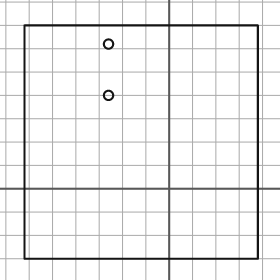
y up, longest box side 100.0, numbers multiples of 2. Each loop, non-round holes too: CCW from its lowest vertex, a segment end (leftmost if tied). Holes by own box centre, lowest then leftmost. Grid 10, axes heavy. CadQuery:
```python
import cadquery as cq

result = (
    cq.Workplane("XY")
    .moveTo(-62.0, -30.0)
    .lineTo(38.0, -30.0)
    .lineTo(38.0, 70.0)
    .lineTo(-62.0, 70.0)
    .close()
    .moveTo(-26.0, 40.0)
    .circle(2.0)
    .moveTo(-26.0, 62.0)
    .circle(2.0)
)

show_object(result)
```